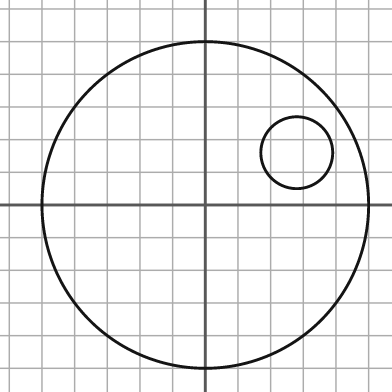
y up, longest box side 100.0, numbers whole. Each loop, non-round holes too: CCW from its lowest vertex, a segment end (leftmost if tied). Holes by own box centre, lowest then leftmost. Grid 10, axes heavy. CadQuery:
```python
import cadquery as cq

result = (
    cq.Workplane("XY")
    .moveTo(0.0, 0.0)
    .circle(50.0)
    .moveTo(28.0, 16.0)
    .circle(11.0)
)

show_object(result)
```